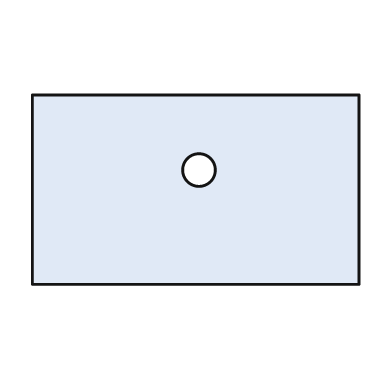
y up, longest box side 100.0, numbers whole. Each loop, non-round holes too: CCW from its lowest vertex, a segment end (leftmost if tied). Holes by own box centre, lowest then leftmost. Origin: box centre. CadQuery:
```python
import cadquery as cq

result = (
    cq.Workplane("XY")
    .moveTo(-50.0, -29.0)
    .lineTo(50.0, -29.0)
    .lineTo(50.0, 29.0)
    .lineTo(-50.0, 29.0)
    .close()
    .moveTo(1.0, 6.0)
    .circle(5.0)
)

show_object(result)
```